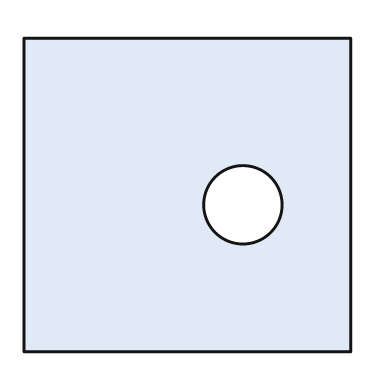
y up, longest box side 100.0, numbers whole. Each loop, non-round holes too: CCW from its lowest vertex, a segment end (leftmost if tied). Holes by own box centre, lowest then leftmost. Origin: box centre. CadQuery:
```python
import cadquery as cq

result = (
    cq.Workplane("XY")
    .moveTo(-50.0, -48.0)
    .lineTo(50.0, -48.0)
    .lineTo(50.0, 48.0)
    .lineTo(-50.0, 48.0)
    .close()
    .moveTo(17.0, -3.0)
    .circle(12.0)
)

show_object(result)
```